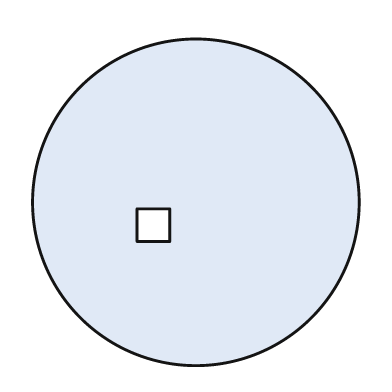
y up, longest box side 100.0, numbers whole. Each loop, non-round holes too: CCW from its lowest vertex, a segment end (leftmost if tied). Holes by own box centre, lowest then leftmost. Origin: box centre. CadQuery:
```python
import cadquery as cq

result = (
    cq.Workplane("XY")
    .moveTo(0.0, 0.0)
    .circle(50.0)
    .moveTo(-18.0, -12.0)
    .lineTo(-8.0, -12.0)
    .lineTo(-8.0, -2.0)
    .lineTo(-18.0, -2.0)
    .close()
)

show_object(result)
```